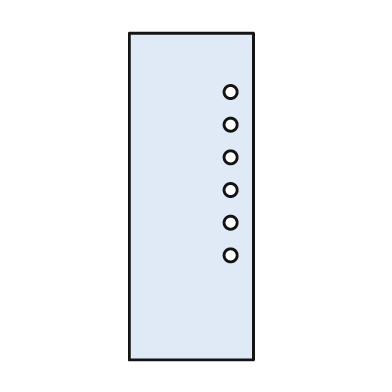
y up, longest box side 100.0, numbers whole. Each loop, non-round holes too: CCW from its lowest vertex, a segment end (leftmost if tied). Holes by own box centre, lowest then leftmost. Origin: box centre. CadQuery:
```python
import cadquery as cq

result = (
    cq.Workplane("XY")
    .moveTo(-19.0, -50.0)
    .lineTo(19.0, -50.0)
    .lineTo(19.0, 50.0)
    .lineTo(-19.0, 50.0)
    .close()
    .moveTo(12.0, -18.0)
    .circle(2.0)
    .moveTo(12.0, -8.0)
    .circle(2.0)
    .moveTo(12.0, 2.0)
    .circle(2.0)
    .moveTo(12.0, 12.0)
    .circle(2.0)
    .moveTo(12.0, 22.0)
    .circle(2.0)
    .moveTo(12.0, 32.0)
    .circle(2.0)
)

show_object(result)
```